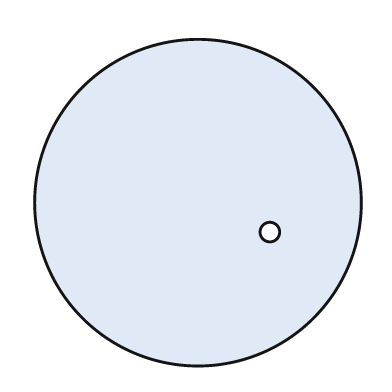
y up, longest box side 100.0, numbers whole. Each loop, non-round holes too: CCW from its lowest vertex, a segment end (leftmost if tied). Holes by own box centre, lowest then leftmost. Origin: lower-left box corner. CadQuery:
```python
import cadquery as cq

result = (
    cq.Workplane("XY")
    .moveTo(50.0, 50.0)
    .circle(50.0)
    .moveTo(72.0, 41.0)
    .circle(3.0)
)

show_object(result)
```